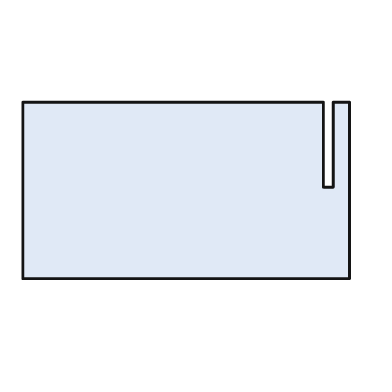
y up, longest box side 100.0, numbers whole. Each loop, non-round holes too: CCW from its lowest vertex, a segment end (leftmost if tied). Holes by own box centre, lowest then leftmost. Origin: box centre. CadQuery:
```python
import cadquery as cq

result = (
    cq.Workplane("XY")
    .moveTo(-50.0, -27.0)
    .lineTo(50.0, -27.0)
    .lineTo(50.0, 27.0)
    .lineTo(45.0, 27.0)
    .lineTo(45.0, 1.0)
    .lineTo(42.0, 1.0)
    .lineTo(42.0, 27.0)
    .lineTo(-50.0, 27.0)
    .close()
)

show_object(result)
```